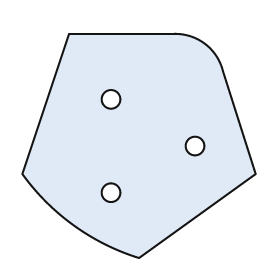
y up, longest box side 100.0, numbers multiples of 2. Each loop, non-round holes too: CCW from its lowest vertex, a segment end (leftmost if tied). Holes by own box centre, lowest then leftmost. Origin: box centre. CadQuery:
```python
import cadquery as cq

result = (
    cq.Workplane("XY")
    .moveTo(0.0, -48.0)
    .lineTo(50.0, -12.0)
    .lineTo(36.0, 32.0)
    .threePointArc((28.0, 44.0), (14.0, 48.0))
    .lineTo(-30.0, 48.0)
    .lineTo(-50.0, -12.0)
    .threePointArc((-28.0, -34.0), (0.0, -48.0))
    .close()
    .moveTo(-12.0, -20.0)
    .circle(4.0)
    .moveTo(24.0, 0.0)
    .circle(4.0)
    .moveTo(-12.0, 20.0)
    .circle(4.0)
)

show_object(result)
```